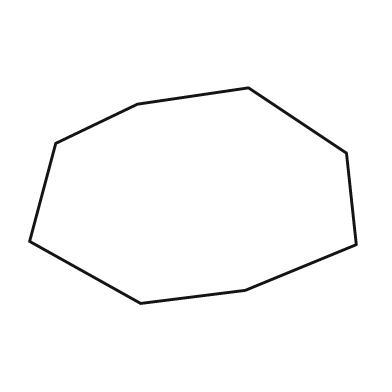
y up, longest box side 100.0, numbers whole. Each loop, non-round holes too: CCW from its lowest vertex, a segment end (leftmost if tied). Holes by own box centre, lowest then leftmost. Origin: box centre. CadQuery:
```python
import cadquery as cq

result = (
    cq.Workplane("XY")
    .moveTo(-16.0, -33.0)
    .lineTo(16.0, -29.0)
    .lineTo(50.0, -15.0)
    .lineTo(47.0, 13.0)
    .lineTo(17.0, 33.0)
    .lineTo(-17.0, 28.0)
    .lineTo(-42.0, 16.0)
    .lineTo(-50.0, -14.0)
    .close()
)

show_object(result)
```